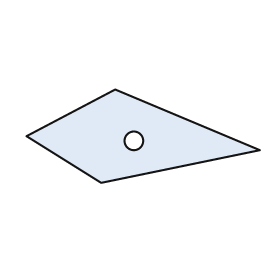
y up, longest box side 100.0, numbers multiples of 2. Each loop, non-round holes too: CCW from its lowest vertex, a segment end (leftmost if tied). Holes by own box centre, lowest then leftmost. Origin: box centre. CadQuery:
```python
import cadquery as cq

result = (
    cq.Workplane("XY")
    .moveTo(-18.0, -20.0)
    .lineTo(50.0, -6.0)
    .lineTo(-12.0, 20.0)
    .lineTo(-50.0, 0.0)
    .close()
    .moveTo(-4.0, -2.0)
    .circle(4.0)
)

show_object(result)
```